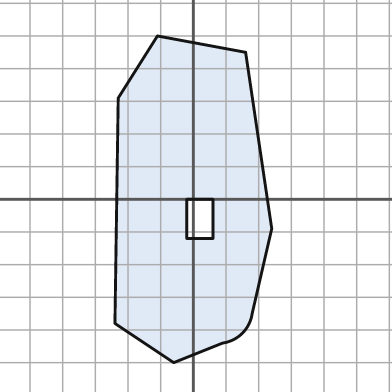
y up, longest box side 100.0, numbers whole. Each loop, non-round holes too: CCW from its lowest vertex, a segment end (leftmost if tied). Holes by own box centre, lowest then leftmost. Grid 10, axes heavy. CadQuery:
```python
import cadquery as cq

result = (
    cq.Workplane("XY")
    .moveTo(-6.0, -50.0)
    .lineTo(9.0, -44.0)
    .threePointArc((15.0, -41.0), (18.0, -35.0))
    .lineTo(24.0, -9.0)
    .lineTo(16.0, 45.0)
    .lineTo(-11.0, 50.0)
    .lineTo(-23.0, 31.0)
    .lineTo(-24.0, -38.0)
    .close()
    .moveTo(-2.0, -12.0)
    .lineTo(6.0, -12.0)
    .lineTo(6.0, 0.0)
    .lineTo(-2.0, 0.0)
    .close()
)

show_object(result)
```